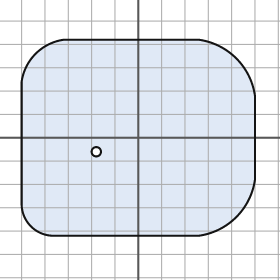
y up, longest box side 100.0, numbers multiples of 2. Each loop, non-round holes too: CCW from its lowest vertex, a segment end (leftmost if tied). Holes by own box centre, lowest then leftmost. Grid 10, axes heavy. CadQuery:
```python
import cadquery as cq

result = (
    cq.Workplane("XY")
    .moveTo(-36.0, -42.0)
    .lineTo(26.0, -42.0)
    .threePointArc((42.0, -34.0), (50.0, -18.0))
    .lineTo(50.0, 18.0)
    .threePointArc((42.0, 34.0), (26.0, 42.0))
    .lineTo(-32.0, 42.0)
    .threePointArc((-44.0, 36.0), (-50.0, 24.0))
    .lineTo(-50.0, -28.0)
    .threePointArc((-46.0, -38.0), (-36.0, -42.0))
    .close()
    .moveTo(-18.0, -6.0)
    .circle(2.0)
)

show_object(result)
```